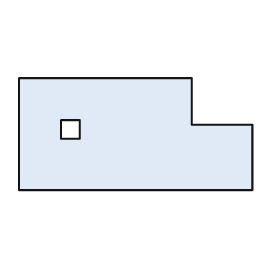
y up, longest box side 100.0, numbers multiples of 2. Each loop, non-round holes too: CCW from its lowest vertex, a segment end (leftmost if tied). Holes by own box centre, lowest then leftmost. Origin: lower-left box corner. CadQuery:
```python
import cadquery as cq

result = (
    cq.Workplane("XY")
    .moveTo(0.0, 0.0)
    .lineTo(100.0, 0.0)
    .lineTo(100.0, 28.0)
    .lineTo(74.0, 28.0)
    .lineTo(74.0, 48.0)
    .lineTo(0.0, 48.0)
    .close()
    .moveTo(18.0, 22.0)
    .lineTo(26.0, 22.0)
    .lineTo(26.0, 30.0)
    .lineTo(18.0, 30.0)
    .close()
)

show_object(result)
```